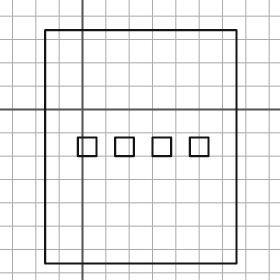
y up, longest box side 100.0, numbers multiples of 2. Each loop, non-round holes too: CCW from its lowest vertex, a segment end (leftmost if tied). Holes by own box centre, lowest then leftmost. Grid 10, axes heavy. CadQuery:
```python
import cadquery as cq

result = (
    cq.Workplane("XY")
    .moveTo(-16.0, -66.0)
    .lineTo(66.0, -66.0)
    .lineTo(66.0, 34.0)
    .lineTo(-16.0, 34.0)
    .close()
    .moveTo(-2.0, -20.0)
    .lineTo(6.0, -20.0)
    .lineTo(6.0, -12.0)
    .lineTo(-2.0, -12.0)
    .close()
    .moveTo(14.0, -20.0)
    .lineTo(22.0, -20.0)
    .lineTo(22.0, -12.0)
    .lineTo(14.0, -12.0)
    .close()
    .moveTo(30.0, -20.0)
    .lineTo(38.0, -20.0)
    .lineTo(38.0, -12.0)
    .lineTo(30.0, -12.0)
    .close()
    .moveTo(46.0, -20.0)
    .lineTo(54.0, -20.0)
    .lineTo(54.0, -12.0)
    .lineTo(46.0, -12.0)
    .close()
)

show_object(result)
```